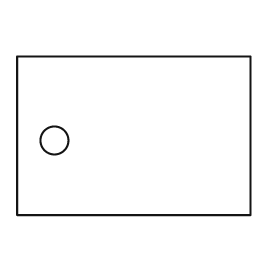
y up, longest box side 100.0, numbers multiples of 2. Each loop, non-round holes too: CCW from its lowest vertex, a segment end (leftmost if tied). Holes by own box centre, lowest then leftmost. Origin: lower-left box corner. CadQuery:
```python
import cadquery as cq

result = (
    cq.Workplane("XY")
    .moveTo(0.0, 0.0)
    .lineTo(100.0, 0.0)
    .lineTo(100.0, 68.0)
    .lineTo(0.0, 68.0)
    .close()
    .moveTo(16.0, 32.0)
    .circle(6.0)
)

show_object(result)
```